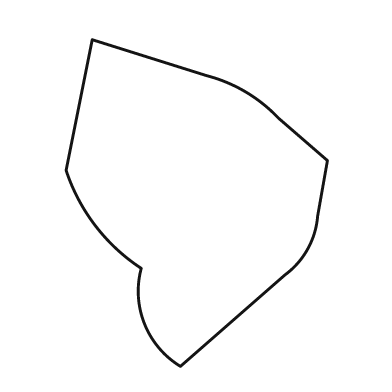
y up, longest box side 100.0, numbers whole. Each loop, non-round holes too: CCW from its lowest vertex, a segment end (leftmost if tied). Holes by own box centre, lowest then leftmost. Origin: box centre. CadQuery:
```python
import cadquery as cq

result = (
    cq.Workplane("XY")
    .moveTo(-5.0, -50.0)
    .lineTo(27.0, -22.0)
    .threePointArc((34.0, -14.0), (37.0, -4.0))
    .lineTo(40.0, 13.0)
    .lineTo(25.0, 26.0)
    .threePointArc((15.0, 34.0), (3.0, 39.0))
    .lineTo(-32.0, 50.0)
    .lineTo(-40.0, 10.0)
    .threePointArc((-31.0, -7.0), (-17.0, -20.0))
    .threePointArc((-16.0, -37.0), (-5.0, -50.0))
    .close()
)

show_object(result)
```